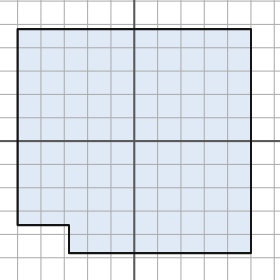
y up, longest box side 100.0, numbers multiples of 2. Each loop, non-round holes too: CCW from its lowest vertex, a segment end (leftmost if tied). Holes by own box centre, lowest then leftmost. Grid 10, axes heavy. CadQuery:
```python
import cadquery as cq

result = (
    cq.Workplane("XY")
    .moveTo(-28.0, -48.0)
    .lineTo(50.0, -48.0)
    .lineTo(50.0, 48.0)
    .lineTo(-50.0, 48.0)
    .lineTo(-50.0, -36.0)
    .lineTo(-28.0, -36.0)
    .close()
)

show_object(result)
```